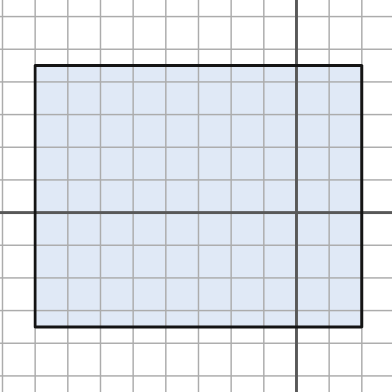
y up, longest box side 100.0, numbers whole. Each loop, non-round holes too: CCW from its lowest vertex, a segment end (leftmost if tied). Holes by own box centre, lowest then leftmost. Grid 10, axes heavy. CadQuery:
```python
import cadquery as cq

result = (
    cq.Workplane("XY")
    .moveTo(-80.0, -35.0)
    .lineTo(20.0, -35.0)
    .lineTo(20.0, 45.0)
    .lineTo(-80.0, 45.0)
    .close()
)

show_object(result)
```